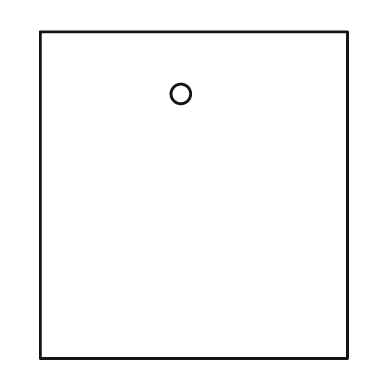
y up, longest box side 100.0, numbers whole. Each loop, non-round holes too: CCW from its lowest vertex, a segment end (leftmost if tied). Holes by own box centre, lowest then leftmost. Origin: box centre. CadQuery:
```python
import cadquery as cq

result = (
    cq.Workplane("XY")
    .moveTo(-47.0, -50.0)
    .lineTo(47.0, -50.0)
    .lineTo(47.0, 50.0)
    .lineTo(-47.0, 50.0)
    .close()
    .moveTo(-4.0, 31.0)
    .circle(3.0)
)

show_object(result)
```